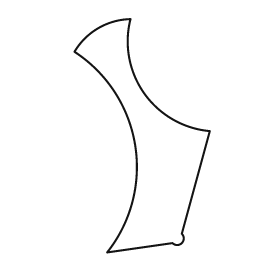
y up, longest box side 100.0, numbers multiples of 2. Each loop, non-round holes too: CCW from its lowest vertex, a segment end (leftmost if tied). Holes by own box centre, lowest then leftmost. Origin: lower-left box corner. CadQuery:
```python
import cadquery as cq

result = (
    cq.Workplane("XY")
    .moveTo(14.0, 0.0)
    .lineTo(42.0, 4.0)
    .threePointArc((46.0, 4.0), (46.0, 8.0))
    .lineTo(58.0, 52.0)
    .threePointArc((30.0, 68.0), (24.0, 100.0))
    .threePointArc((10.0, 96.0), (0.0, 86.0))
    .threePointArc((26.0, 46.0), (14.0, 0.0))
    .close()
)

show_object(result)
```